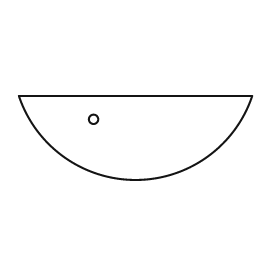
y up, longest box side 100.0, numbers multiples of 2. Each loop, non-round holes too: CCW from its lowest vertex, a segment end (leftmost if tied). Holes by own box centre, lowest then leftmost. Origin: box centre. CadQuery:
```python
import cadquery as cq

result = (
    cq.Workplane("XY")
    .moveTo(-50.0, 18.0)
    .threePointArc((0.0, -18.0), (50.0, 18.0))
    .close()
    .moveTo(-18.0, 8.0)
    .circle(2.0)
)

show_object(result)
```